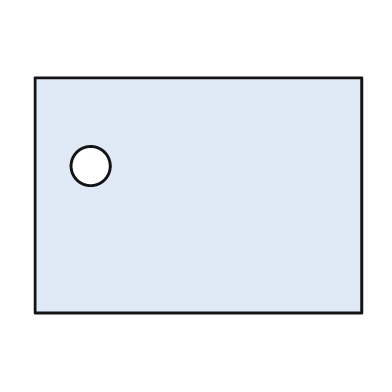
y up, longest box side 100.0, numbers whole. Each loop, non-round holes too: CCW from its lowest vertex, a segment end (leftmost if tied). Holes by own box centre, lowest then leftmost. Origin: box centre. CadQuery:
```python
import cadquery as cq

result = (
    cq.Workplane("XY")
    .moveTo(-50.0, -36.0)
    .lineTo(50.0, -36.0)
    .lineTo(50.0, 36.0)
    .lineTo(-50.0, 36.0)
    .close()
    .moveTo(-33.0, 9.0)
    .circle(6.0)
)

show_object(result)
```